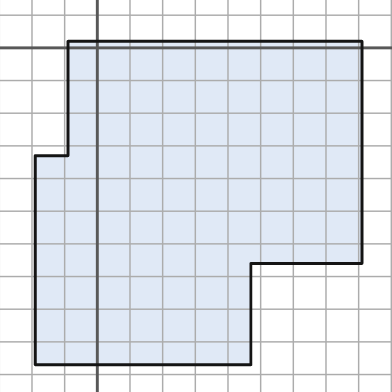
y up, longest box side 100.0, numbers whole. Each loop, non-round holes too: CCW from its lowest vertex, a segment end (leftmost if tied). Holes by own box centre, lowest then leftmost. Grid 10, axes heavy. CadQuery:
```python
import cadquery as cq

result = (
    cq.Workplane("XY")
    .moveTo(-19.0, -97.0)
    .lineTo(47.0, -97.0)
    .lineTo(47.0, -66.0)
    .lineTo(81.0, -66.0)
    .lineTo(81.0, 2.0)
    .lineTo(-9.0, 2.0)
    .lineTo(-9.0, -33.0)
    .lineTo(-19.0, -33.0)
    .close()
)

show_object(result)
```